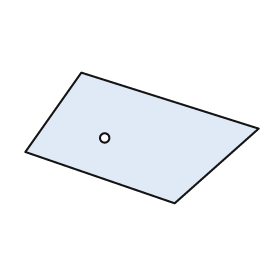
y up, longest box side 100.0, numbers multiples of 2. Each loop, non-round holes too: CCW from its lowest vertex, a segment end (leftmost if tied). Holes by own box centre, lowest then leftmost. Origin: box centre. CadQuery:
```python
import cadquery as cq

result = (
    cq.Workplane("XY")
    .moveTo(14.0, -28.0)
    .lineTo(50.0, 4.0)
    .lineTo(-26.0, 28.0)
    .lineTo(-50.0, -6.0)
    .close()
    .moveTo(-16.0, 0.0)
    .circle(2.0)
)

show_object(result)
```